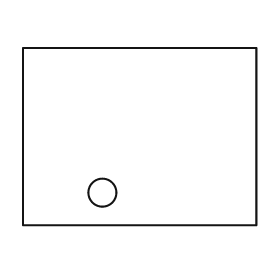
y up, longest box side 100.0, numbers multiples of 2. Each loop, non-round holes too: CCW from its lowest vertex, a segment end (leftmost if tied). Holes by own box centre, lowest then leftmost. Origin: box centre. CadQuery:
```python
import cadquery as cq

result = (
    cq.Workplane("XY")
    .moveTo(-50.0, -38.0)
    .lineTo(50.0, -38.0)
    .lineTo(50.0, 38.0)
    .lineTo(-50.0, 38.0)
    .close()
    .moveTo(-16.0, -24.0)
    .circle(6.0)
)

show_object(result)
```